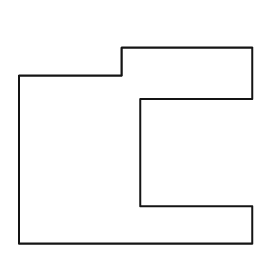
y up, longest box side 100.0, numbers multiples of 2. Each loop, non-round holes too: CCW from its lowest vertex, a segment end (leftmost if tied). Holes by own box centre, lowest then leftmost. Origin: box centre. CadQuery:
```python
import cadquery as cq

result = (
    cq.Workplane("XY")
    .moveTo(-50.0, -42.0)
    .lineTo(50.0, -42.0)
    .lineTo(50.0, -26.0)
    .lineTo(2.0, -26.0)
    .lineTo(2.0, 20.0)
    .lineTo(50.0, 20.0)
    .lineTo(50.0, 42.0)
    .lineTo(-6.0, 42.0)
    .lineTo(-6.0, 30.0)
    .lineTo(-50.0, 30.0)
    .close()
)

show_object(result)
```